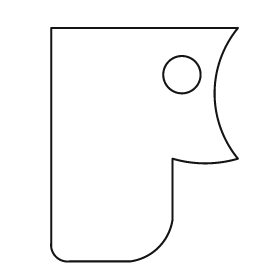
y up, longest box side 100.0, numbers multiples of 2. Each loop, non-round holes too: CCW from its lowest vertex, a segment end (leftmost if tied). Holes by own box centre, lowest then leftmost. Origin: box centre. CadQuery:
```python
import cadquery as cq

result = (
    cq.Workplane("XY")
    .moveTo(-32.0, -50.0)
    .lineTo(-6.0, -50.0)
    .threePointArc((6.0, -44.0), (12.0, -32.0))
    .lineTo(12.0, -6.0)
    .threePointArc((26.0, -8.0), (40.0, -6.0))
    .threePointArc((30.0, 22.0), (40.0, 50.0))
    .lineTo(-40.0, 50.0)
    .lineTo(-40.0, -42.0)
    .threePointArc((-38.0, -48.0), (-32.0, -50.0))
    .close()
    .moveTo(16.0, 30.0)
    .circle(8.0)
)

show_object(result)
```